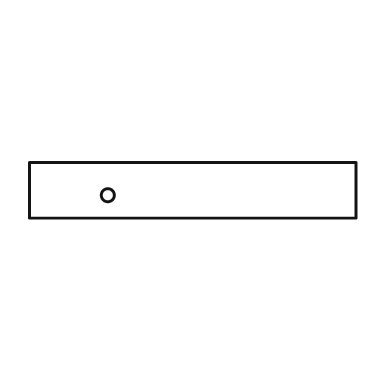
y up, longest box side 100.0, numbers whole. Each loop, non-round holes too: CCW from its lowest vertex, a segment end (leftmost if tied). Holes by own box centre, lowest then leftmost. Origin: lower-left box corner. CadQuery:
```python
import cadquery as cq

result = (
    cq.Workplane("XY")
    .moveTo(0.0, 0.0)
    .lineTo(100.0, 0.0)
    .lineTo(100.0, 17.0)
    .lineTo(0.0, 17.0)
    .close()
    .moveTo(24.0, 7.0)
    .circle(2.0)
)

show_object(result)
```